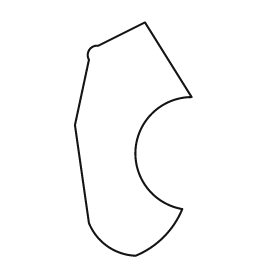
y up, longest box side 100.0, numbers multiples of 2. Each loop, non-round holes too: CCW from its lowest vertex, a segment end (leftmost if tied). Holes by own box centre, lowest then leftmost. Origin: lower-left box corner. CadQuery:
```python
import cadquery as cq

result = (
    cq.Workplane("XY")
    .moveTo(26.0, 0.0)
    .threePointArc((38.0, 8.0), (46.0, 20.0))
    .threePointArc((26.0, 46.0), (50.0, 68.0))
    .lineTo(30.0, 100.0)
    .lineTo(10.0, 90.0)
    .threePointArc((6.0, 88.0), (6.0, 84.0))
    .lineTo(0.0, 56.0)
    .lineTo(6.0, 14.0)
    .threePointArc((14.0, 4.0), (26.0, 0.0))
    .close()
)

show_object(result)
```